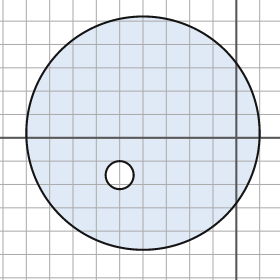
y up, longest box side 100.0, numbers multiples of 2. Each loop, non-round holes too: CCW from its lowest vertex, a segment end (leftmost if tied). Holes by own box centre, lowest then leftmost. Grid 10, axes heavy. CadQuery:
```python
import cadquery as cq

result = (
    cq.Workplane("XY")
    .moveTo(-40.0, 2.0)
    .circle(50.0)
    .moveTo(-50.0, -16.0)
    .circle(6.0)
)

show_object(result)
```